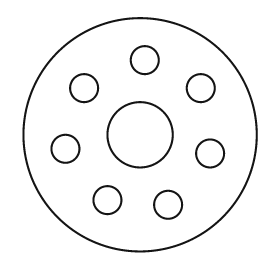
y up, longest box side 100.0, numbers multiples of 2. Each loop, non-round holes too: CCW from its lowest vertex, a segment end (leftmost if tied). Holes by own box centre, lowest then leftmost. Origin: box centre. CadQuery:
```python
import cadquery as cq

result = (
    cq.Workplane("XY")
    .moveTo(0.0, 0.0)
    .circle(50.0)
    .moveTo(12.0, -30.0)
    .circle(6.0)
    .moveTo(-14.0, -28.0)
    .circle(6.0)
    .moveTo(30.0, -8.0)
    .circle(6.0)
    .moveTo(-32.0, -6.0)
    .circle(6.0)
    .moveTo(0.0, 0.0)
    .circle(14.0)
    .moveTo(-24.0, 20.0)
    .circle(6.0)
    .moveTo(26.0, 20.0)
    .circle(6.0)
    .moveTo(2.0, 32.0)
    .circle(6.0)
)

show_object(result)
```